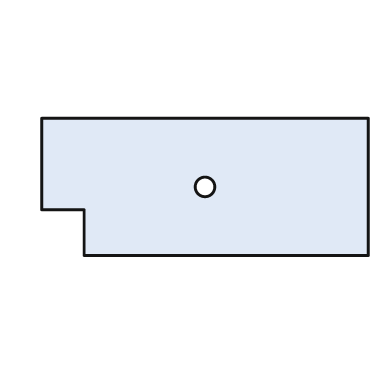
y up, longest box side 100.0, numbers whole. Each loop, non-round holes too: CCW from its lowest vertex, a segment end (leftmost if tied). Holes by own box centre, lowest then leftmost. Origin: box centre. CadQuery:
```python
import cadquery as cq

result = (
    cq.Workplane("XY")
    .moveTo(-37.0, -21.0)
    .lineTo(50.0, -21.0)
    .lineTo(50.0, 21.0)
    .lineTo(-50.0, 21.0)
    .lineTo(-50.0, -7.0)
    .lineTo(-37.0, -7.0)
    .close()
    .moveTo(0.0, 0.0)
    .circle(3.0)
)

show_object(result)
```